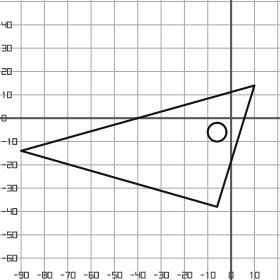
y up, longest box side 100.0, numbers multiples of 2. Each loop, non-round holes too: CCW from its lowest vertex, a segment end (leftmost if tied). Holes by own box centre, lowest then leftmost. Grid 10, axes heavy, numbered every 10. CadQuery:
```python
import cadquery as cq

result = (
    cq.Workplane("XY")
    .moveTo(-6.0, -38.0)
    .lineTo(10.0, 14.0)
    .lineTo(-90.0, -14.0)
    .close()
    .moveTo(-6.0, -6.0)
    .circle(4.0)
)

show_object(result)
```